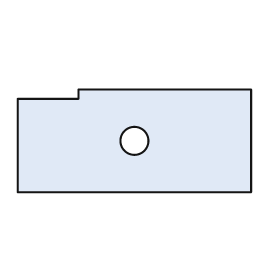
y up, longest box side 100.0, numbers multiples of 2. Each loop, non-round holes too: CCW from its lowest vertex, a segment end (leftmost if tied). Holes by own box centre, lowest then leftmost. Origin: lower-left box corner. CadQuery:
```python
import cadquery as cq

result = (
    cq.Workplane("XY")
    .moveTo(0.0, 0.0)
    .lineTo(100.0, 0.0)
    .lineTo(100.0, 44.0)
    .lineTo(26.0, 44.0)
    .lineTo(26.0, 40.0)
    .lineTo(0.0, 40.0)
    .close()
    .moveTo(50.0, 22.0)
    .circle(6.0)
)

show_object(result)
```